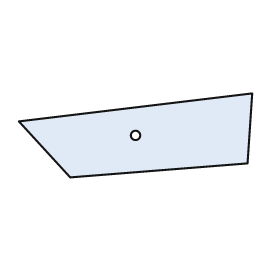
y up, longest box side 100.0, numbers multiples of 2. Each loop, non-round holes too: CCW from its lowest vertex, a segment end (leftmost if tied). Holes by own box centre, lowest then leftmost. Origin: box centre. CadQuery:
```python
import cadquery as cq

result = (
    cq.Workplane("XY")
    .moveTo(-28.0, -18.0)
    .lineTo(48.0, -12.0)
    .lineTo(50.0, 18.0)
    .lineTo(-50.0, 6.0)
    .close()
    .moveTo(0.0, 0.0)
    .circle(2.0)
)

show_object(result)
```